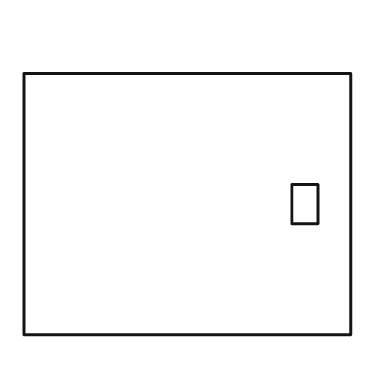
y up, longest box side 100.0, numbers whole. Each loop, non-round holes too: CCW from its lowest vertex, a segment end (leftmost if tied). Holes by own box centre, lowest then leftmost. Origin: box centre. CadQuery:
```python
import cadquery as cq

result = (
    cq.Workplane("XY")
    .moveTo(-50.0, -40.0)
    .lineTo(50.0, -40.0)
    .lineTo(50.0, 40.0)
    .lineTo(-50.0, 40.0)
    .close()
    .moveTo(32.0, -6.0)
    .lineTo(40.0, -6.0)
    .lineTo(40.0, 6.0)
    .lineTo(32.0, 6.0)
    .close()
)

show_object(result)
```